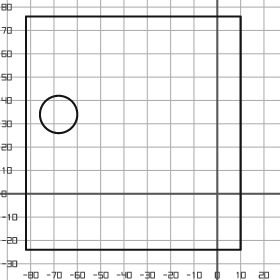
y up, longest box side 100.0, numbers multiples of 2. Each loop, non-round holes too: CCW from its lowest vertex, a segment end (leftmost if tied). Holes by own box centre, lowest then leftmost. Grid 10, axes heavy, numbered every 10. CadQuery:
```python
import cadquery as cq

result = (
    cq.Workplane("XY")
    .moveTo(-82.0, -24.0)
    .lineTo(10.0, -24.0)
    .lineTo(10.0, 76.0)
    .lineTo(-82.0, 76.0)
    .close()
    .moveTo(-68.0, 34.0)
    .circle(8.0)
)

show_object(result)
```